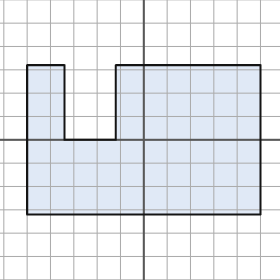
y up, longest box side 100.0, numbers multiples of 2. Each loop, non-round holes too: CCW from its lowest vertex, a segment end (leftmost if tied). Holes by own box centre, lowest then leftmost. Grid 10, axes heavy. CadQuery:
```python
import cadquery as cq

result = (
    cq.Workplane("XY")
    .moveTo(-50.0, -32.0)
    .lineTo(50.0, -32.0)
    .lineTo(50.0, 32.0)
    .lineTo(-12.0, 32.0)
    .lineTo(-12.0, 0.0)
    .lineTo(-34.0, 0.0)
    .lineTo(-34.0, 32.0)
    .lineTo(-50.0, 32.0)
    .close()
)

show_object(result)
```